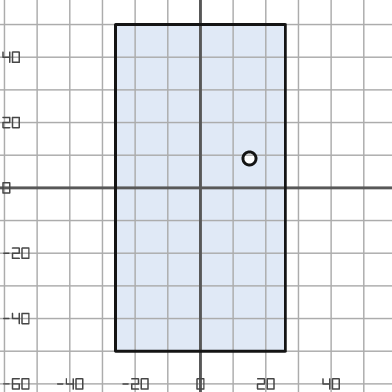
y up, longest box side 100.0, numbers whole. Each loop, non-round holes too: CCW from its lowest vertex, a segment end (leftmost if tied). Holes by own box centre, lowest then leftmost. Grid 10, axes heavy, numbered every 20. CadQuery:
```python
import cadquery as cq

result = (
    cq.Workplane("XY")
    .moveTo(-26.0, -50.0)
    .lineTo(26.0, -50.0)
    .lineTo(26.0, 50.0)
    .lineTo(-26.0, 50.0)
    .close()
    .moveTo(15.0, 9.0)
    .circle(2.0)
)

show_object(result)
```